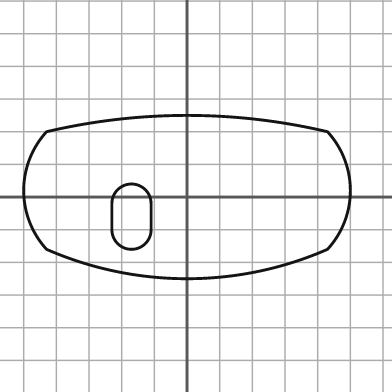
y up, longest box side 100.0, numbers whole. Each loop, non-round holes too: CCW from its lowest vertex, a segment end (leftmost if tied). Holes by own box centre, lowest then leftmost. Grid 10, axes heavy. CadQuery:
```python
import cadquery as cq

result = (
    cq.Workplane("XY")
    .moveTo(-43.0, -16.0)
    .threePointArc((0.0, -25.0), (43.0, -16.0))
    .threePointArc((50.0, 2.0), (43.0, 20.0))
    .threePointArc((0.0, 25.0), (-43.0, 20.0))
    .threePointArc((-50.0, 2.0), (-43.0, -16.0))
    .close()
    .moveTo(-23.0, -10.0)
    .threePointArc((-17.0, -16.0), (-11.0, -10.0))
    .lineTo(-11.0, -2.0)
    .threePointArc((-17.0, 4.0), (-23.0, -2.0))
    .close()
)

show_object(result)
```